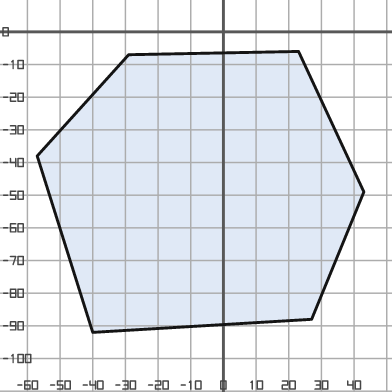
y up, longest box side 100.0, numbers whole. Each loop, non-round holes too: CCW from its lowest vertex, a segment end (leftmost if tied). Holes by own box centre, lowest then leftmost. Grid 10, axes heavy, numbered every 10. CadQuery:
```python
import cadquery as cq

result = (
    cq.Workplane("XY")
    .moveTo(-40.0, -92.0)
    .lineTo(27.0, -88.0)
    .lineTo(43.0, -49.0)
    .lineTo(23.0, -6.0)
    .lineTo(-29.0, -7.0)
    .lineTo(-57.0, -38.0)
    .close()
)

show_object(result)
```